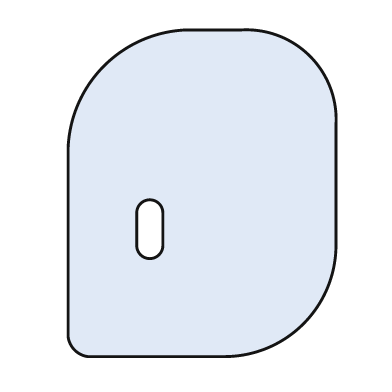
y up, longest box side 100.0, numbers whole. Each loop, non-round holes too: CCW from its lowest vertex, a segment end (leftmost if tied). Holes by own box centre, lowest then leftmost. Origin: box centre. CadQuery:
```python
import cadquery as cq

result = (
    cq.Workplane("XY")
    .moveTo(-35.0, -50.0)
    .lineTo(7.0, -50.0)
    .threePointArc((31.0, -40.0), (41.0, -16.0))
    .lineTo(41.0, 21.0)
    .threePointArc((33.0, 42.0), (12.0, 50.0))
    .lineTo(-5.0, 50.0)
    .threePointArc((-30.0, 39.0), (-41.0, 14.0))
    .lineTo(-41.0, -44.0)
    .threePointArc((-39.0, -48.0), (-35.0, -50.0))
    .close()
    .moveTo(-20.0, -16.0)
    .threePointArc((-16.0, -20.0), (-12.0, -16.0))
    .lineTo(-12.0, -6.0)
    .threePointArc((-16.0, -2.0), (-20.0, -6.0))
    .close()
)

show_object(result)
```